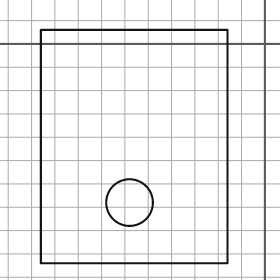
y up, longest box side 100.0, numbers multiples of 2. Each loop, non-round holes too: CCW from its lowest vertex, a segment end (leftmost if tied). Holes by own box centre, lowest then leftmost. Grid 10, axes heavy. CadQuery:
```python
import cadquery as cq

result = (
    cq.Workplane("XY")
    .moveTo(-96.0, -94.0)
    .lineTo(-16.0, -94.0)
    .lineTo(-16.0, 6.0)
    .lineTo(-96.0, 6.0)
    .close()
    .moveTo(-58.0, -68.0)
    .circle(10.0)
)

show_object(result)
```